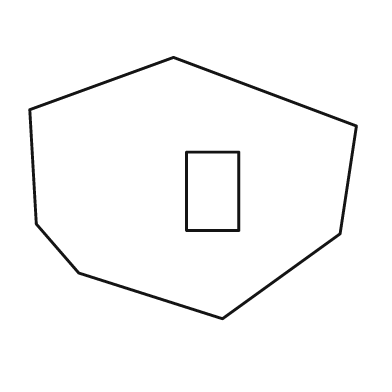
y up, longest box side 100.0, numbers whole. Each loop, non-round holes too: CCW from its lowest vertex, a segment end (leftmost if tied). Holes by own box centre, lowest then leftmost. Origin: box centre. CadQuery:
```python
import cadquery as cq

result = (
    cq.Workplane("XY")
    .moveTo(9.0, -40.0)
    .lineTo(45.0, -14.0)
    .lineTo(50.0, 19.0)
    .lineTo(-6.0, 40.0)
    .lineTo(-50.0, 24.0)
    .lineTo(-48.0, -11.0)
    .lineTo(-35.0, -26.0)
    .close()
    .moveTo(-2.0, -13.0)
    .lineTo(14.0, -13.0)
    .lineTo(14.0, 11.0)
    .lineTo(-2.0, 11.0)
    .close()
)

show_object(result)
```